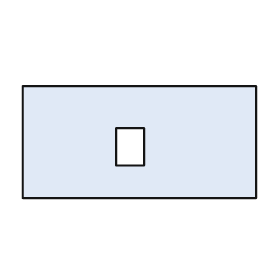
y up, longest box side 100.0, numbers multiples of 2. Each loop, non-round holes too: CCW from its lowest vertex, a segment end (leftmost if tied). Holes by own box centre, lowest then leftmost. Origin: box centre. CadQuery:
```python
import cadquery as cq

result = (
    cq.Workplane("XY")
    .moveTo(-50.0, -24.0)
    .lineTo(50.0, -24.0)
    .lineTo(50.0, 24.0)
    .lineTo(-50.0, 24.0)
    .close()
    .moveTo(-10.0, -10.0)
    .lineTo(2.0, -10.0)
    .lineTo(2.0, 6.0)
    .lineTo(-10.0, 6.0)
    .close()
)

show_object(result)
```